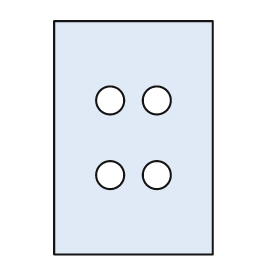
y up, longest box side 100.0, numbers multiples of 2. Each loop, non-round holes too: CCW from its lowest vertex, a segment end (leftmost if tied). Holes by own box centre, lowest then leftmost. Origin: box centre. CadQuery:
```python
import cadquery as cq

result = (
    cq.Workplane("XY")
    .moveTo(-34.0, -50.0)
    .lineTo(34.0, -50.0)
    .lineTo(34.0, 50.0)
    .lineTo(-34.0, 50.0)
    .close()
    .moveTo(-10.0, -16.0)
    .circle(6.0)
    .moveTo(10.0, -16.0)
    .circle(6.0)
    .moveTo(-10.0, 16.0)
    .circle(6.0)
    .moveTo(10.0, 16.0)
    .circle(6.0)
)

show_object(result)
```